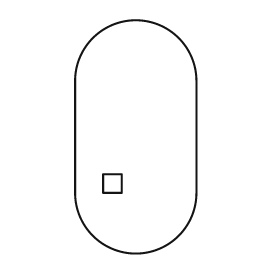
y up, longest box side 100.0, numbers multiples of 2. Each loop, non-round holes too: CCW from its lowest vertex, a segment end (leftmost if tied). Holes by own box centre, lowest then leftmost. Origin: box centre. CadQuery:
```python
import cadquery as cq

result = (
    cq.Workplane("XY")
    .moveTo(-26.0, -24.0)
    .threePointArc((0.0, -50.0), (26.0, -24.0))
    .lineTo(26.0, 24.0)
    .threePointArc((0.0, 50.0), (-26.0, 24.0))
    .close()
    .moveTo(-14.0, -24.0)
    .lineTo(-6.0, -24.0)
    .lineTo(-6.0, -16.0)
    .lineTo(-14.0, -16.0)
    .close()
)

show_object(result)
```